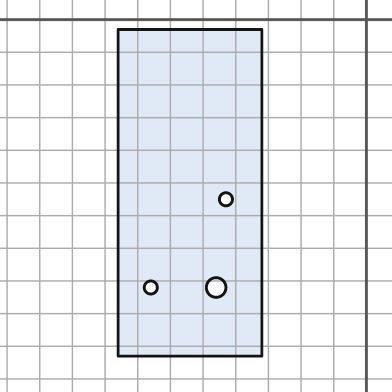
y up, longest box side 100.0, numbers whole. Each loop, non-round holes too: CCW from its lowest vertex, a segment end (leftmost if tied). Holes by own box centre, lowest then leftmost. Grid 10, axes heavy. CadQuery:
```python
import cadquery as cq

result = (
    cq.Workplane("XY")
    .moveTo(-76.0, -103.0)
    .lineTo(-32.0, -103.0)
    .lineTo(-32.0, -3.0)
    .lineTo(-76.0, -3.0)
    .close()
    .moveTo(-66.0, -82.0)
    .circle(2.0)
    .moveTo(-46.0, -82.0)
    .circle(3.0)
    .moveTo(-43.0, -55.0)
    .circle(2.0)
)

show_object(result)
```